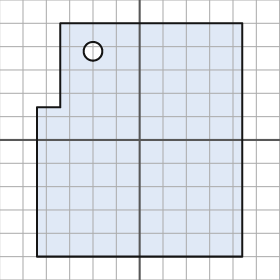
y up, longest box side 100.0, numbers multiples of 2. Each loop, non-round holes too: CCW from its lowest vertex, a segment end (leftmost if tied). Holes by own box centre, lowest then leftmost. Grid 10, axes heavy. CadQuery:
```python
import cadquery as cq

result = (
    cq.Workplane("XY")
    .moveTo(-44.0, -50.0)
    .lineTo(44.0, -50.0)
    .lineTo(44.0, 50.0)
    .lineTo(-34.0, 50.0)
    .lineTo(-34.0, 14.0)
    .lineTo(-44.0, 14.0)
    .close()
    .moveTo(-20.0, 38.0)
    .circle(4.0)
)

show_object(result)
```